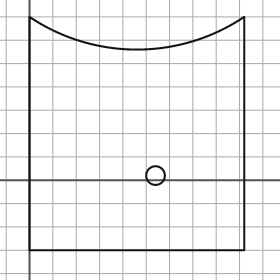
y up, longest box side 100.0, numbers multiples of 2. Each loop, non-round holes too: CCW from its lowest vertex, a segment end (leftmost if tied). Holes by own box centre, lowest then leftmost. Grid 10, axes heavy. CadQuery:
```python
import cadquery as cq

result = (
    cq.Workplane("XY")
    .moveTo(0.0, -30.0)
    .lineTo(92.0, -30.0)
    .lineTo(92.0, 70.0)
    .threePointArc((46.0, 56.0), (0.0, 70.0))
    .close()
    .moveTo(54.0, 2.0)
    .circle(4.0)
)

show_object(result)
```